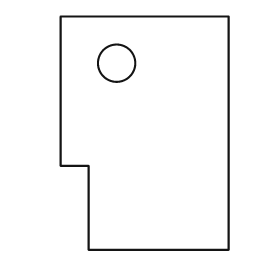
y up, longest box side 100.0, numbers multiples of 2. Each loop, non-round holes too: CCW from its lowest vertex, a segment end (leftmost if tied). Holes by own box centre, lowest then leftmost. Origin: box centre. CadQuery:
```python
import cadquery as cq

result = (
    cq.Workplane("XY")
    .moveTo(-24.0, -50.0)
    .lineTo(36.0, -50.0)
    .lineTo(36.0, 50.0)
    .lineTo(-36.0, 50.0)
    .lineTo(-36.0, -14.0)
    .lineTo(-24.0, -14.0)
    .close()
    .moveTo(-12.0, 30.0)
    .circle(8.0)
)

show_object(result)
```